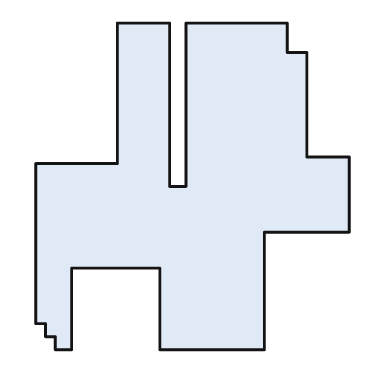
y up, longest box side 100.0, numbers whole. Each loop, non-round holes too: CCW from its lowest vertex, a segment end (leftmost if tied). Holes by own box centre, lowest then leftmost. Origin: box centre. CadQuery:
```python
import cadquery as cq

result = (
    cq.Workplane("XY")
    .moveTo(-42.0, -50.0)
    .lineTo(-37.0, -50.0)
    .lineTo(-37.0, -25.0)
    .lineTo(-10.0, -25.0)
    .lineTo(-10.0, -50.0)
    .lineTo(22.0, -50.0)
    .lineTo(22.0, -14.0)
    .lineTo(48.0, -14.0)
    .lineTo(48.0, 9.0)
    .lineTo(35.0, 9.0)
    .lineTo(35.0, 41.0)
    .lineTo(29.0, 41.0)
    .lineTo(29.0, 50.0)
    .lineTo(-2.0, 50.0)
    .lineTo(-2.0, 0.0)
    .lineTo(-7.0, 0.0)
    .lineTo(-7.0, 50.0)
    .lineTo(-23.0, 50.0)
    .lineTo(-23.0, 7.0)
    .lineTo(-48.0, 7.0)
    .lineTo(-48.0, -42.0)
    .lineTo(-45.0, -42.0)
    .lineTo(-45.0, -46.0)
    .lineTo(-42.0, -46.0)
    .close()
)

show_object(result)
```